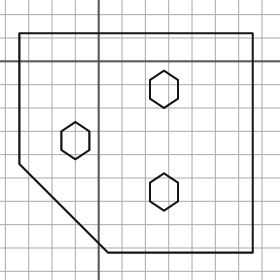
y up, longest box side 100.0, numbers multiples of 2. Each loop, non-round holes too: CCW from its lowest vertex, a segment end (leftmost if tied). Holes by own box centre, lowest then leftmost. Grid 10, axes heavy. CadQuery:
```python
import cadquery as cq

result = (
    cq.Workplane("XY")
    .moveTo(4.0, -82.0)
    .lineTo(66.0, -82.0)
    .lineTo(66.0, 12.0)
    .lineTo(-34.0, 12.0)
    .lineTo(-34.0, -44.0)
    .close()
    .moveTo(28.0, -64.0)
    .lineTo(34.0, -60.0)
    .lineTo(34.0, -52.0)
    .lineTo(28.0, -48.0)
    .lineTo(22.0, -52.0)
    .lineTo(22.0, -60.0)
    .close()
    .moveTo(-10.0, -42.0)
    .lineTo(-4.0, -38.0)
    .lineTo(-4.0, -30.0)
    .lineTo(-10.0, -26.0)
    .lineTo(-16.0, -30.0)
    .lineTo(-16.0, -38.0)
    .close()
    .moveTo(28.0, -20.0)
    .lineTo(34.0, -16.0)
    .lineTo(34.0, -8.0)
    .lineTo(28.0, -4.0)
    .lineTo(22.0, -8.0)
    .lineTo(22.0, -16.0)
    .close()
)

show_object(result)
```